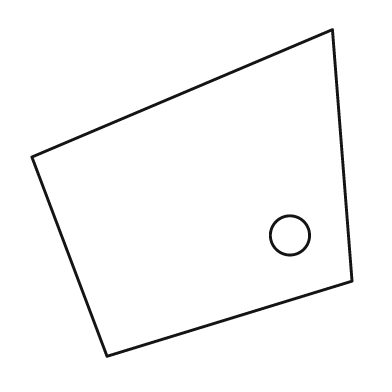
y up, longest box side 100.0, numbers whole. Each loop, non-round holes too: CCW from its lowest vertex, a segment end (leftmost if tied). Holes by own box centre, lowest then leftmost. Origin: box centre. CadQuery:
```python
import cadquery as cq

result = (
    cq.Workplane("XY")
    .moveTo(-26.0, -50.0)
    .lineTo(49.0, -27.0)
    .lineTo(43.0, 50.0)
    .lineTo(-49.0, 11.0)
    .close()
    .moveTo(30.0, -13.0)
    .circle(6.0)
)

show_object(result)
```